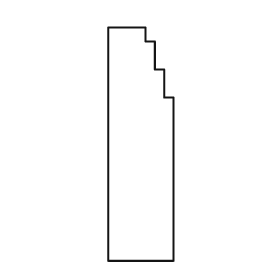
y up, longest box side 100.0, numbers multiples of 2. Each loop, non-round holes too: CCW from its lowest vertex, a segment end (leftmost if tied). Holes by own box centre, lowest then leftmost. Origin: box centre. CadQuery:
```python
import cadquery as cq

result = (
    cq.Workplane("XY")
    .moveTo(-14.0, -50.0)
    .lineTo(14.0, -50.0)
    .lineTo(14.0, 20.0)
    .lineTo(10.0, 20.0)
    .lineTo(10.0, 32.0)
    .lineTo(6.0, 32.0)
    .lineTo(6.0, 44.0)
    .lineTo(2.0, 44.0)
    .lineTo(2.0, 50.0)
    .lineTo(-14.0, 50.0)
    .close()
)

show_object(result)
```